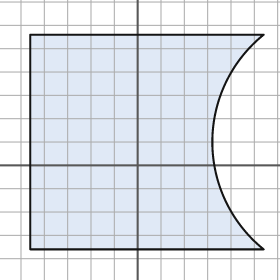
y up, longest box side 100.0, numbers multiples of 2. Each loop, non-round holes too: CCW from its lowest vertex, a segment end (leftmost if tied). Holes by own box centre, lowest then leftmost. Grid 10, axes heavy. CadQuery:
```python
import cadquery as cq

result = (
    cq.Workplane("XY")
    .moveTo(-46.0, -36.0)
    .lineTo(54.0, -36.0)
    .threePointArc((32.0, 10.0), (54.0, 56.0))
    .lineTo(-46.0, 56.0)
    .close()
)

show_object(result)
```